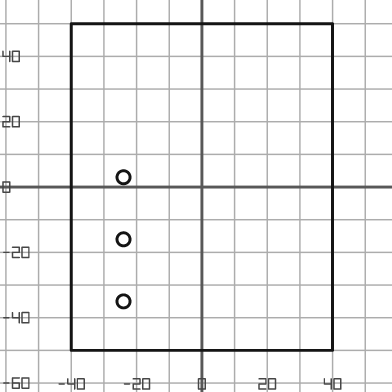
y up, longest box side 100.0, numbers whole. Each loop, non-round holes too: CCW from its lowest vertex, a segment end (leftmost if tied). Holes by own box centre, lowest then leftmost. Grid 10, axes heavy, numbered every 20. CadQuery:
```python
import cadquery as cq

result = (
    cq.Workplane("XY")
    .moveTo(-40.0, -50.0)
    .lineTo(40.0, -50.0)
    .lineTo(40.0, 50.0)
    .lineTo(-40.0, 50.0)
    .close()
    .moveTo(-24.0, -35.0)
    .circle(2.0)
    .moveTo(-24.0, -16.0)
    .circle(2.0)
    .moveTo(-24.0, 3.0)
    .circle(2.0)
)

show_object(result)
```